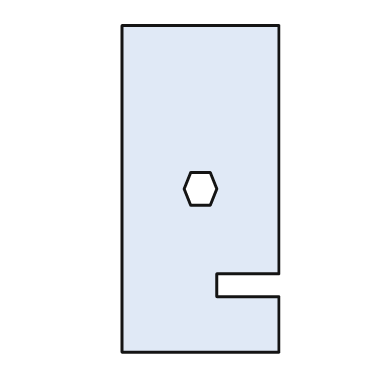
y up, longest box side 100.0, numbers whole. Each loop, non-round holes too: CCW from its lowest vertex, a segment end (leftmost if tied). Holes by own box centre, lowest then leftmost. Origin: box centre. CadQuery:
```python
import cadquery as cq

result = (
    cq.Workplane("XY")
    .moveTo(-24.0, -50.0)
    .lineTo(24.0, -50.0)
    .lineTo(24.0, -33.0)
    .lineTo(5.0, -33.0)
    .lineTo(5.0, -26.0)
    .lineTo(24.0, -26.0)
    .lineTo(24.0, 50.0)
    .lineTo(-24.0, 50.0)
    .close()
    .moveTo(-3.0, -5.0)
    .lineTo(3.0, -5.0)
    .lineTo(5.0, 0.0)
    .lineTo(3.0, 5.0)
    .lineTo(-3.0, 5.0)
    .lineTo(-5.0, 0.0)
    .close()
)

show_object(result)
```